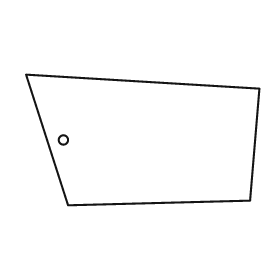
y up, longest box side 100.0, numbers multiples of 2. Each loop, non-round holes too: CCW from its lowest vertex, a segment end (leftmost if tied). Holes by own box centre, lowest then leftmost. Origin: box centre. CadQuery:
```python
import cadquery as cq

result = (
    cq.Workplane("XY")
    .moveTo(-32.0, -28.0)
    .lineTo(46.0, -26.0)
    .lineTo(50.0, 22.0)
    .lineTo(-50.0, 28.0)
    .close()
    .moveTo(-34.0, 0.0)
    .circle(2.0)
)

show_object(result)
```